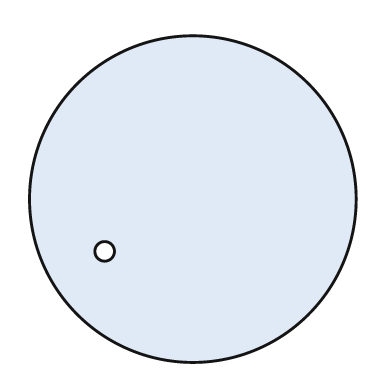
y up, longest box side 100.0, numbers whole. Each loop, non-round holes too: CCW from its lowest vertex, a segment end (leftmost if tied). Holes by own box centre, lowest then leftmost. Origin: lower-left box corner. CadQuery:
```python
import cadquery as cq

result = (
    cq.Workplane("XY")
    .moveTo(50.0, 50.0)
    .circle(50.0)
    .moveTo(23.0, 34.0)
    .circle(3.0)
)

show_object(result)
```